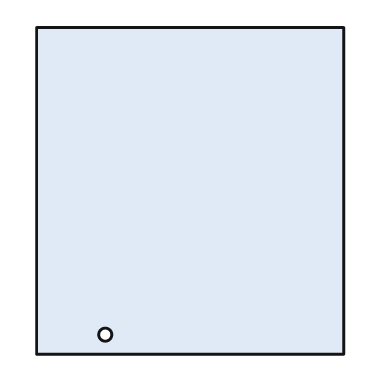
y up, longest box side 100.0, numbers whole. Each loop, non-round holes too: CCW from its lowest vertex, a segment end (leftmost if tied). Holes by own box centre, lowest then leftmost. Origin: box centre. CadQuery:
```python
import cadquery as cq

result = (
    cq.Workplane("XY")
    .moveTo(-47.0, -50.0)
    .lineTo(47.0, -50.0)
    .lineTo(47.0, 50.0)
    .lineTo(-47.0, 50.0)
    .close()
    .moveTo(-26.0, -44.0)
    .circle(2.0)
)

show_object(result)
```